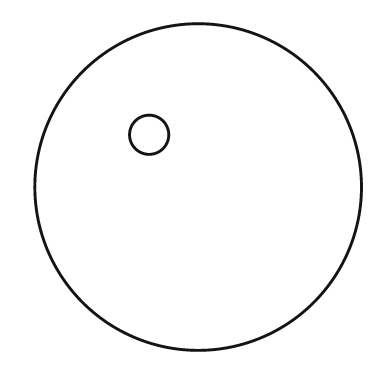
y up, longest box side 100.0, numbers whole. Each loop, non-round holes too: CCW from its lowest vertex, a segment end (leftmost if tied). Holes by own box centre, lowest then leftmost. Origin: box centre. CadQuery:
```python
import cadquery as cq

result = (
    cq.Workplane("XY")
    .moveTo(0.0, 0.0)
    .circle(50.0)
    .moveTo(-15.0, 16.0)
    .circle(6.0)
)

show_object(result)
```